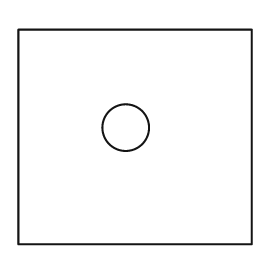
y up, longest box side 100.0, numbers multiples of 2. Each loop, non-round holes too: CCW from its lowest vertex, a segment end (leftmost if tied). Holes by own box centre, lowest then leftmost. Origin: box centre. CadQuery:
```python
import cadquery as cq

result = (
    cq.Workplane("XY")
    .moveTo(-50.0, -46.0)
    .lineTo(50.0, -46.0)
    .lineTo(50.0, 46.0)
    .lineTo(-50.0, 46.0)
    .close()
    .moveTo(-4.0, 4.0)
    .circle(10.0)
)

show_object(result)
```